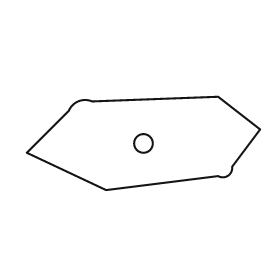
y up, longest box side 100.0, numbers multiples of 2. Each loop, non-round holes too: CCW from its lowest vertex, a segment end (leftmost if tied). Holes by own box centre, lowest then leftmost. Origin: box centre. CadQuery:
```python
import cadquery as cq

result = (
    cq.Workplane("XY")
    .moveTo(-16.0, -20.0)
    .lineTo(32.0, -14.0)
    .threePointArc((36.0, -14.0), (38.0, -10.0))
    .lineTo(50.0, 6.0)
    .lineTo(32.0, 20.0)
    .lineTo(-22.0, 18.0)
    .threePointArc((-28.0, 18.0), (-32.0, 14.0))
    .lineTo(-50.0, -4.0)
    .close()
    .moveTo(0.0, 0.0)
    .circle(4.0)
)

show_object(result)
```